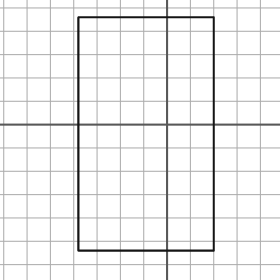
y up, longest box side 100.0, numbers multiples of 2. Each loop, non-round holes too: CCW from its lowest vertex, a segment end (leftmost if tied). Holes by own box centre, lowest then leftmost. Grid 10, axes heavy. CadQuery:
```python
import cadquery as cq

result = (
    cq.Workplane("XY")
    .moveTo(-38.0, -54.0)
    .lineTo(20.0, -54.0)
    .lineTo(20.0, 46.0)
    .lineTo(-38.0, 46.0)
    .close()
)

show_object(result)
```